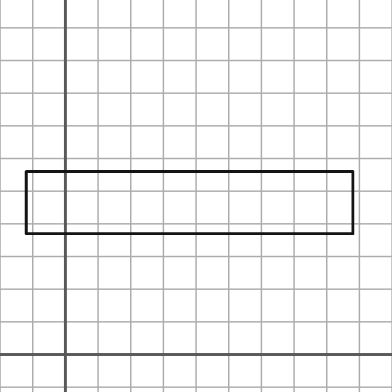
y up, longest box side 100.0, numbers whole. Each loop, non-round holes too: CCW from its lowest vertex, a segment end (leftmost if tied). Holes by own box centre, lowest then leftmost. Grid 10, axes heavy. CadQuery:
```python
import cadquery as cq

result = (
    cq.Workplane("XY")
    .moveTo(-12.0, 37.0)
    .lineTo(88.0, 37.0)
    .lineTo(88.0, 56.0)
    .lineTo(-12.0, 56.0)
    .close()
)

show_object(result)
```